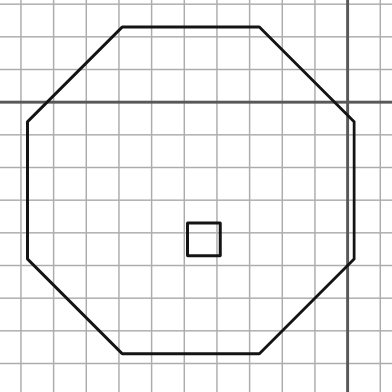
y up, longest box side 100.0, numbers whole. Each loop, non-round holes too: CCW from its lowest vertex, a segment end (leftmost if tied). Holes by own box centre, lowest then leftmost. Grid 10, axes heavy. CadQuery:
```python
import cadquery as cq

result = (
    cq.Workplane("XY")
    .moveTo(-69.0, -77.0)
    .lineTo(-27.0, -77.0)
    .lineTo(2.0, -48.0)
    .lineTo(2.0, -6.0)
    .lineTo(-27.0, 23.0)
    .lineTo(-69.0, 23.0)
    .lineTo(-98.0, -6.0)
    .lineTo(-98.0, -48.0)
    .close()
    .moveTo(-49.0, -47.0)
    .lineTo(-39.0, -47.0)
    .lineTo(-39.0, -37.0)
    .lineTo(-49.0, -37.0)
    .close()
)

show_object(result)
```